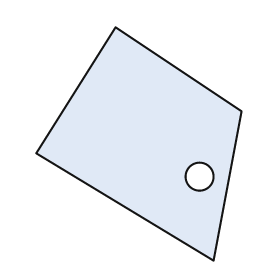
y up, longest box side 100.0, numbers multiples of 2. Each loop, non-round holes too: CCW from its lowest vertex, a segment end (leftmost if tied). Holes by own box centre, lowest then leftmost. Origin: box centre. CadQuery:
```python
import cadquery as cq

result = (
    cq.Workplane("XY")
    .moveTo(32.0, -50.0)
    .lineTo(44.0, 14.0)
    .lineTo(-10.0, 50.0)
    .lineTo(-44.0, -4.0)
    .close()
    .moveTo(26.0, -14.0)
    .circle(6.0)
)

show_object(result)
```